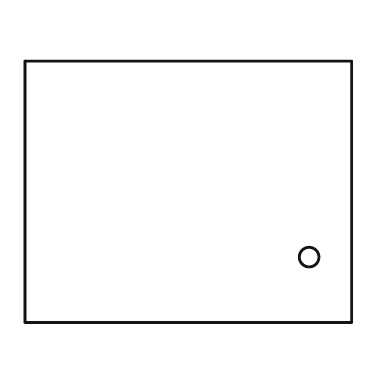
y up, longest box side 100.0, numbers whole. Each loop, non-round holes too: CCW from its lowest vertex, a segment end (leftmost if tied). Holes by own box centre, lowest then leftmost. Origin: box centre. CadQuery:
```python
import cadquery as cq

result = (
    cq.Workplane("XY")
    .moveTo(-50.0, -40.0)
    .lineTo(50.0, -40.0)
    .lineTo(50.0, 40.0)
    .lineTo(-50.0, 40.0)
    .close()
    .moveTo(37.0, -20.0)
    .circle(3.0)
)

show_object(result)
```